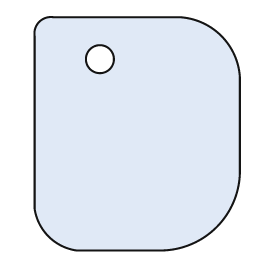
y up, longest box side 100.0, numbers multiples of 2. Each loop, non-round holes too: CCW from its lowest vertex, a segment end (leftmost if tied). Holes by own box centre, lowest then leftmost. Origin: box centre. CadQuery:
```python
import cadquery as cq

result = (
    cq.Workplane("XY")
    .moveTo(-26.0, -50.0)
    .lineTo(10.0, -50.0)
    .threePointArc((34.0, -40.0), (44.0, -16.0))
    .lineTo(44.0, 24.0)
    .threePointArc((36.0, 42.0), (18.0, 50.0))
    .lineTo(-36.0, 50.0)
    .threePointArc((-42.0, 48.0), (-44.0, 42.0))
    .lineTo(-44.0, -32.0)
    .threePointArc((-38.0, -44.0), (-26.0, -50.0))
    .close()
    .moveTo(-16.0, 32.0)
    .circle(6.0)
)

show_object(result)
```